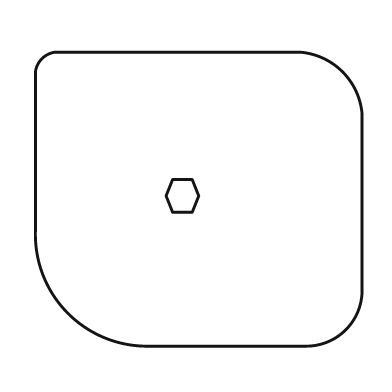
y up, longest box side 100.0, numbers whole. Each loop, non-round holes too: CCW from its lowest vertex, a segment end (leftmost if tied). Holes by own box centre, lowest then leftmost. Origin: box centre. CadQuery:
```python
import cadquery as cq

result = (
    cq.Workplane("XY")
    .moveTo(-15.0, -45.0)
    .lineTo(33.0, -45.0)
    .threePointArc((45.0, -40.0), (50.0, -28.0))
    .lineTo(50.0, 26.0)
    .threePointArc((44.0, 39.0), (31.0, 45.0))
    .lineTo(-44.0, 45.0)
    .threePointArc((-48.0, 43.0), (-50.0, 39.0))
    .lineTo(-50.0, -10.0)
    .threePointArc((-40.0, -35.0), (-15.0, -45.0))
    .close()
    .moveTo(-8.0, -4.0)
    .lineTo(-2.0, -4.0)
    .lineTo(0.0, 1.0)
    .lineTo(-2.0, 6.0)
    .lineTo(-8.0, 6.0)
    .lineTo(-10.0, 1.0)
    .close()
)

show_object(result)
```